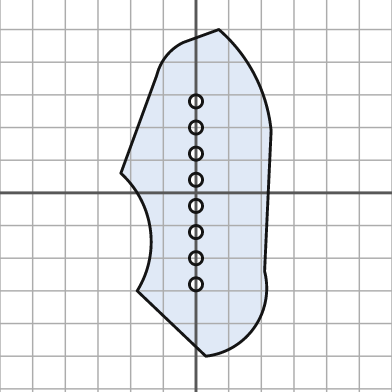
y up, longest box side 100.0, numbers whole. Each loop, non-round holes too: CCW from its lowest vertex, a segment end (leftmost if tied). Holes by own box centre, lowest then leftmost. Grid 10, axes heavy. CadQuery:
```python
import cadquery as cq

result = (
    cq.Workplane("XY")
    .moveTo(3.0, -50.0)
    .threePointArc((18.0, -41.0), (21.0, -24.0))
    .lineTo(23.0, 19.0)
    .threePointArc((18.0, 36.0), (7.0, 50.0))
    .lineTo(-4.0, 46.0)
    .threePointArc((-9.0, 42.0), (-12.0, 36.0))
    .lineTo(-23.0, 6.0)
    .threePointArc((-14.0, -11.0), (-18.0, -30.0))
    .close()
    .moveTo(0.0, -28.0)
    .circle(2.0)
    .moveTo(0.0, -20.0)
    .circle(2.0)
    .moveTo(0.0, -12.0)
    .circle(2.0)
    .moveTo(0.0, -4.0)
    .circle(2.0)
    .moveTo(0.0, 4.0)
    .circle(2.0)
    .moveTo(0.0, 12.0)
    .circle(2.0)
    .moveTo(0.0, 20.0)
    .circle(2.0)
    .moveTo(0.0, 28.0)
    .circle(2.0)
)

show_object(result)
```